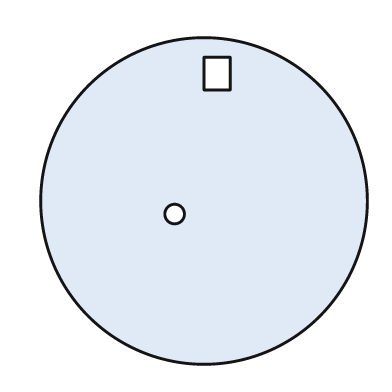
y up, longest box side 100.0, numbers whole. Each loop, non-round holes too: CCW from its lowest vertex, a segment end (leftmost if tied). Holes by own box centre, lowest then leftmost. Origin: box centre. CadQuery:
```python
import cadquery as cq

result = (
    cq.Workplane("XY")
    .moveTo(0.0, 0.0)
    .circle(50.0)
    .moveTo(-9.0, -4.0)
    .circle(3.0)
    .moveTo(0.0, 34.0)
    .lineTo(8.0, 34.0)
    .lineTo(8.0, 44.0)
    .lineTo(0.0, 44.0)
    .close()
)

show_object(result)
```